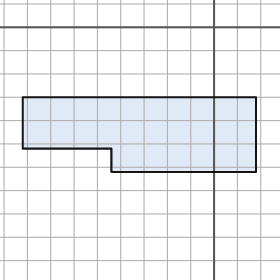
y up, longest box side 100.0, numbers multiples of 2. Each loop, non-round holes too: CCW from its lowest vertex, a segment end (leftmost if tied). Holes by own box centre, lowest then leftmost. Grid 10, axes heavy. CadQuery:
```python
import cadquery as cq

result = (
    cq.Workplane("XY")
    .moveTo(-44.0, -62.0)
    .lineTo(18.0, -62.0)
    .lineTo(18.0, -30.0)
    .lineTo(-82.0, -30.0)
    .lineTo(-82.0, -52.0)
    .lineTo(-44.0, -52.0)
    .close()
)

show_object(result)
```